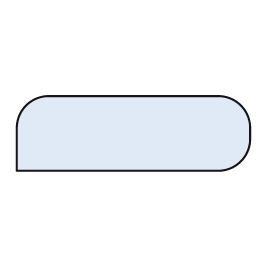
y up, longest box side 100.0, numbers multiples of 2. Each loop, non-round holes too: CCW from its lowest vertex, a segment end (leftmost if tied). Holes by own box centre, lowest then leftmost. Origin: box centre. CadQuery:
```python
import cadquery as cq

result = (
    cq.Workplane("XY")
    .moveTo(-50.0, -16.0)
    .lineTo(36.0, -16.0)
    .threePointArc((46.0, -12.0), (50.0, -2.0))
    .lineTo(50.0, 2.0)
    .threePointArc((46.0, 12.0), (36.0, 16.0))
    .lineTo(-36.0, 16.0)
    .threePointArc((-46.0, 12.0), (-50.0, 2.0))
    .close()
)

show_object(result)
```